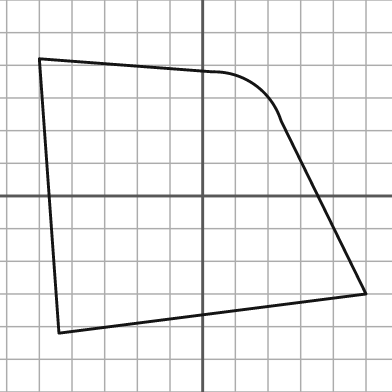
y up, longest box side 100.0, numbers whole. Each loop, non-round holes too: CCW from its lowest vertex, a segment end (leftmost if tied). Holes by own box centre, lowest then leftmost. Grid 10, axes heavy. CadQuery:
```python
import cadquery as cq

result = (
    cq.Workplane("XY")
    .moveTo(-44.0, -42.0)
    .lineTo(50.0, -30.0)
    .lineTo(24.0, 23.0)
    .threePointArc((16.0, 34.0), (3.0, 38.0))
    .lineTo(-50.0, 42.0)
    .close()
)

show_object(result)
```